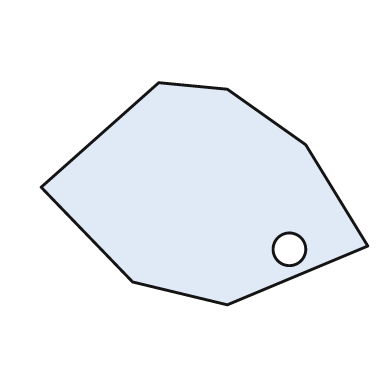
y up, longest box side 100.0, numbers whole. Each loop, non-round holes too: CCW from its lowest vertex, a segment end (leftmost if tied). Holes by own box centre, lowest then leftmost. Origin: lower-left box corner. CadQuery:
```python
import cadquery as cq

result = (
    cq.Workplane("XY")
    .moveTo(57.0, 0.0)
    .lineTo(100.0, 18.0)
    .lineTo(81.0, 49.0)
    .lineTo(57.0, 66.0)
    .lineTo(36.0, 68.0)
    .lineTo(0.0, 36.0)
    .lineTo(28.0, 7.0)
    .close()
    .moveTo(76.0, 17.0)
    .circle(5.0)
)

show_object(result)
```